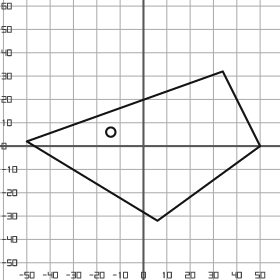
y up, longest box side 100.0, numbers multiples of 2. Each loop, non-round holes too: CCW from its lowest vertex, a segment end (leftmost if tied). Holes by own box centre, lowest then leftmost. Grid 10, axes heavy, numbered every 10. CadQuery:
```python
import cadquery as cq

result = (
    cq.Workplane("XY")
    .moveTo(6.0, -32.0)
    .lineTo(50.0, 0.0)
    .lineTo(34.0, 32.0)
    .lineTo(-50.0, 2.0)
    .close()
    .moveTo(-14.0, 6.0)
    .circle(2.0)
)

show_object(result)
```